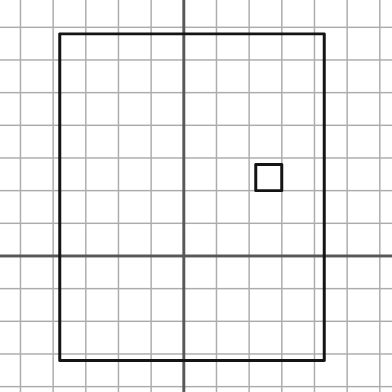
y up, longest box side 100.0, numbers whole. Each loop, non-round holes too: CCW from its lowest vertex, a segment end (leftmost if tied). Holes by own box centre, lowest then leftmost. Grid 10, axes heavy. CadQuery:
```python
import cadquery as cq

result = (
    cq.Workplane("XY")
    .moveTo(-38.0, -32.0)
    .lineTo(43.0, -32.0)
    .lineTo(43.0, 68.0)
    .lineTo(-38.0, 68.0)
    .close()
    .moveTo(22.0, 20.0)
    .lineTo(30.0, 20.0)
    .lineTo(30.0, 28.0)
    .lineTo(22.0, 28.0)
    .close()
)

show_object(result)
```